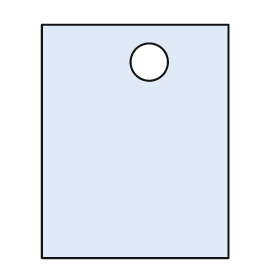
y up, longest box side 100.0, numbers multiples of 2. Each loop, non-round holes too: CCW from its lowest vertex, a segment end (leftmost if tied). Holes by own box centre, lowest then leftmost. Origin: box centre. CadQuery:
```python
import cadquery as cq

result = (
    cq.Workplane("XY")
    .moveTo(-40.0, -50.0)
    .lineTo(40.0, -50.0)
    .lineTo(40.0, 50.0)
    .lineTo(-40.0, 50.0)
    .close()
    .moveTo(6.0, 34.0)
    .circle(8.0)
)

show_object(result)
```